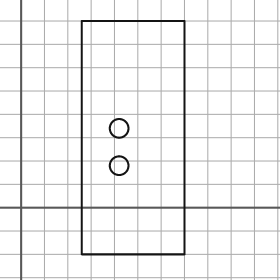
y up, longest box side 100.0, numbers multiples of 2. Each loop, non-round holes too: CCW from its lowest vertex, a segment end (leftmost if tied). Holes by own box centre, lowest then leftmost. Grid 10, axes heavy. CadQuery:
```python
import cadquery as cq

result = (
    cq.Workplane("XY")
    .moveTo(26.0, -20.0)
    .lineTo(70.0, -20.0)
    .lineTo(70.0, 80.0)
    .lineTo(26.0, 80.0)
    .close()
    .moveTo(42.0, 18.0)
    .circle(4.0)
    .moveTo(42.0, 34.0)
    .circle(4.0)
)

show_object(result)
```